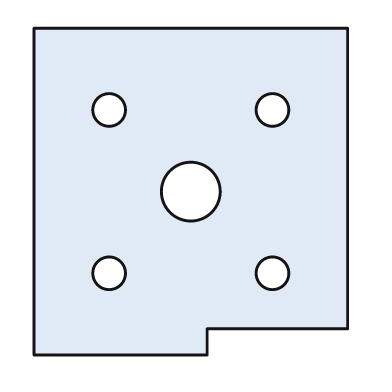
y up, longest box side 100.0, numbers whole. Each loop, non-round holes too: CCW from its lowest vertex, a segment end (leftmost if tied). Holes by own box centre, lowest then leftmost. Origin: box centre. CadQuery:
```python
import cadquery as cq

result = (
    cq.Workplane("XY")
    .moveTo(-48.0, -50.0)
    .lineTo(5.0, -50.0)
    .lineTo(5.0, -42.0)
    .lineTo(48.0, -42.0)
    .lineTo(48.0, 50.0)
    .lineTo(-48.0, 50.0)
    .close()
    .moveTo(-25.0, -25.0)
    .circle(5.0)
    .moveTo(25.0, -25.0)
    .circle(5.0)
    .moveTo(0.0, 0.0)
    .circle(9.0)
    .moveTo(-25.0, 25.0)
    .circle(5.0)
    .moveTo(25.0, 25.0)
    .circle(5.0)
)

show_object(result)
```